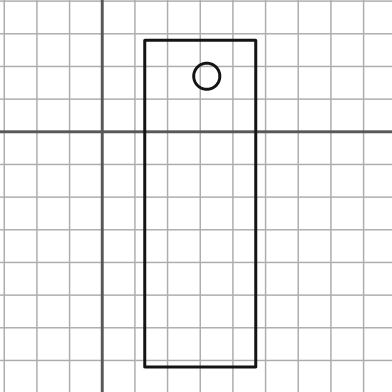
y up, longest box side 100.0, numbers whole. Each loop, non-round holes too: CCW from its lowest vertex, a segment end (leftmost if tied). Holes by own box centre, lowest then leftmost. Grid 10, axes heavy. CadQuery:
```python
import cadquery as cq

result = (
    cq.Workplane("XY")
    .moveTo(13.0, -72.0)
    .lineTo(47.0, -72.0)
    .lineTo(47.0, 28.0)
    .lineTo(13.0, 28.0)
    .close()
    .moveTo(32.0, 17.0)
    .circle(4.0)
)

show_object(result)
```